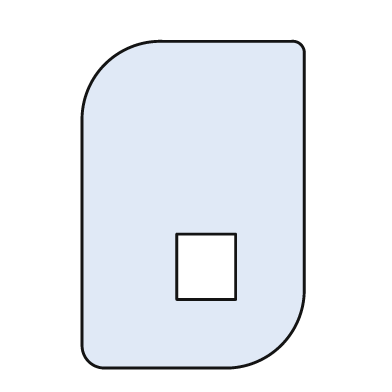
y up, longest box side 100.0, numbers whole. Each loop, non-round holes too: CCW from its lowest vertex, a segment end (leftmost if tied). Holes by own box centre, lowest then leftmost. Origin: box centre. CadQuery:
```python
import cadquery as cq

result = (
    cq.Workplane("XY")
    .moveTo(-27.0, -50.0)
    .lineTo(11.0, -50.0)
    .threePointArc((27.0, -43.0), (34.0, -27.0))
    .lineTo(34.0, 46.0)
    .threePointArc((33.0, 49.0), (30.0, 50.0))
    .lineTo(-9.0, 50.0)
    .threePointArc((-27.0, 43.0), (-34.0, 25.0))
    .lineTo(-34.0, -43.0)
    .threePointArc((-32.0, -48.0), (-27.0, -50.0))
    .close()
    .moveTo(-5.0, -29.0)
    .lineTo(13.0, -29.0)
    .lineTo(13.0, -9.0)
    .lineTo(-5.0, -9.0)
    .close()
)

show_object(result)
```